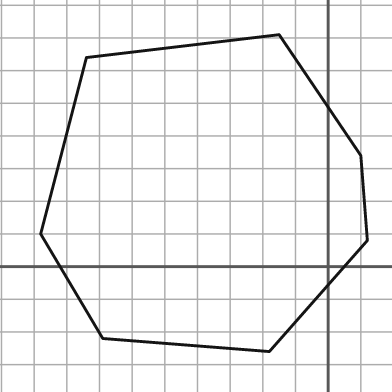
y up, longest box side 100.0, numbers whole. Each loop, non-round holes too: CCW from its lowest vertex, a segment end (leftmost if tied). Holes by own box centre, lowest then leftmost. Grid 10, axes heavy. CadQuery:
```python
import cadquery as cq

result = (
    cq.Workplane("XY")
    .moveTo(-18.0, -26.0)
    .lineTo(12.0, 8.0)
    .lineTo(10.0, 34.0)
    .lineTo(-15.0, 71.0)
    .lineTo(-74.0, 64.0)
    .lineTo(-88.0, 10.0)
    .lineTo(-69.0, -22.0)
    .close()
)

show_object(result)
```